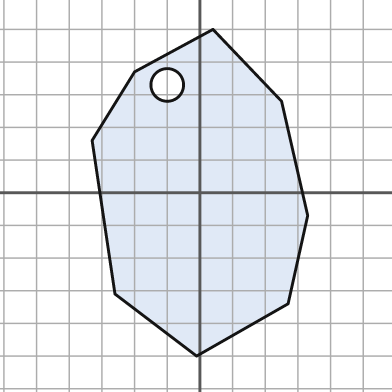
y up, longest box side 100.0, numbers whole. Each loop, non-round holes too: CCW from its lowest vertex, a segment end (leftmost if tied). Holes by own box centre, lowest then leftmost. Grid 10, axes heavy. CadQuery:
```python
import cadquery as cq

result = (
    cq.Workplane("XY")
    .moveTo(-1.0, -50.0)
    .lineTo(27.0, -34.0)
    .lineTo(33.0, -7.0)
    .lineTo(25.0, 28.0)
    .lineTo(4.0, 50.0)
    .lineTo(-20.0, 37.0)
    .lineTo(-33.0, 16.0)
    .lineTo(-26.0, -31.0)
    .close()
    .moveTo(-10.0, 33.0)
    .circle(5.0)
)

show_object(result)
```